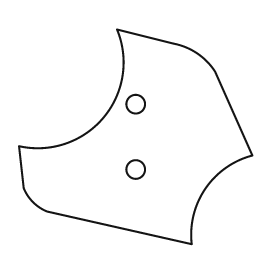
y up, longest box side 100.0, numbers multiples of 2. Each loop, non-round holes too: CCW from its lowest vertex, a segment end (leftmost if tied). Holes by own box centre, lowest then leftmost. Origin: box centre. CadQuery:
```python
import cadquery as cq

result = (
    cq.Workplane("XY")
    .moveTo(24.0, -46.0)
    .threePointArc((30.0, -22.0), (50.0, -8.0))
    .lineTo(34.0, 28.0)
    .threePointArc((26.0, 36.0), (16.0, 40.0))
    .lineTo(-8.0, 46.0)
    .threePointArc((-14.0, 8.0), (-50.0, -4.0))
    .lineTo(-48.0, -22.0)
    .threePointArc((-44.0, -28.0), (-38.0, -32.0))
    .close()
    .moveTo(0.0, -14.0)
    .circle(4.0)
    .moveTo(0.0, 14.0)
    .circle(4.0)
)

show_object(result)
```